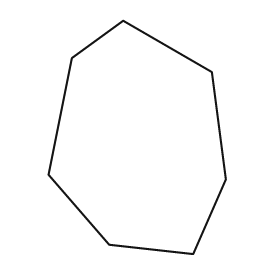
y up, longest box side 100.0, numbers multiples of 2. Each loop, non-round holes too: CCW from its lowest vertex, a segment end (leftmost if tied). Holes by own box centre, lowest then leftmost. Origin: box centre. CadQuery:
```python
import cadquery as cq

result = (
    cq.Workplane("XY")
    .moveTo(24.0, -50.0)
    .lineTo(38.0, -18.0)
    .lineTo(32.0, 28.0)
    .lineTo(-6.0, 50.0)
    .lineTo(-28.0, 34.0)
    .lineTo(-38.0, -16.0)
    .lineTo(-12.0, -46.0)
    .close()
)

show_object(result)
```